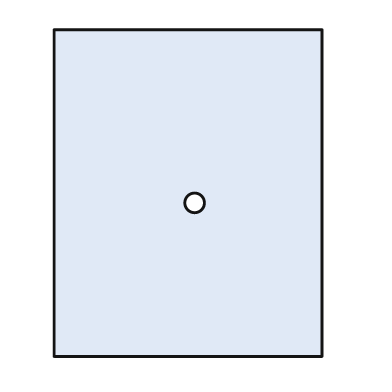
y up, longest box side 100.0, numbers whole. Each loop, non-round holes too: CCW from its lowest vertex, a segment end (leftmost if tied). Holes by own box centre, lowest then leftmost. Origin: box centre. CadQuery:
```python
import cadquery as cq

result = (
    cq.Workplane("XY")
    .moveTo(-41.0, -50.0)
    .lineTo(41.0, -50.0)
    .lineTo(41.0, 50.0)
    .lineTo(-41.0, 50.0)
    .close()
    .moveTo(2.0, -3.0)
    .circle(3.0)
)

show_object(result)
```